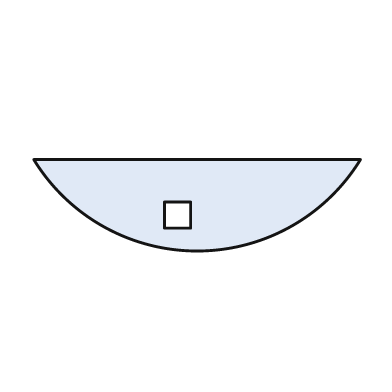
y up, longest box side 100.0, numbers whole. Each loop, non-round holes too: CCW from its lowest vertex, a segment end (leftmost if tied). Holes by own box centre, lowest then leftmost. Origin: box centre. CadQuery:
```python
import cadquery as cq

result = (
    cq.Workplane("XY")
    .moveTo(-50.0, 14.0)
    .threePointArc((0.0, -14.0), (50.0, 14.0))
    .close()
    .moveTo(-10.0, -7.0)
    .lineTo(-2.0, -7.0)
    .lineTo(-2.0, 1.0)
    .lineTo(-10.0, 1.0)
    .close()
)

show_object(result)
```